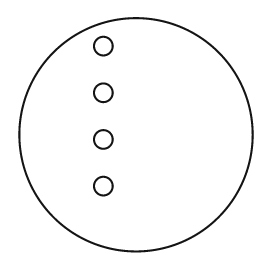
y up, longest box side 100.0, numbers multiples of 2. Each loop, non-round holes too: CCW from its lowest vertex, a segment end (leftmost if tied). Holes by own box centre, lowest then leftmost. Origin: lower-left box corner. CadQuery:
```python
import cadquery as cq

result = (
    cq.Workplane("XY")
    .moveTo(50.0, 50.0)
    .circle(50.0)
    .moveTo(36.0, 28.0)
    .circle(4.0)
    .moveTo(36.0, 48.0)
    .circle(4.0)
    .moveTo(36.0, 68.0)
    .circle(4.0)
    .moveTo(36.0, 88.0)
    .circle(4.0)
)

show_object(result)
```